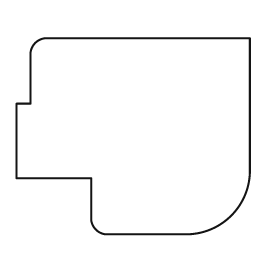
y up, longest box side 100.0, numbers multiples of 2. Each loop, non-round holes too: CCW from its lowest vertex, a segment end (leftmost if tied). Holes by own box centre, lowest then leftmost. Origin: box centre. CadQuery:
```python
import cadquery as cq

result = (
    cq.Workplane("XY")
    .moveTo(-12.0, -42.0)
    .lineTo(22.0, -42.0)
    .threePointArc((42.0, -34.0), (50.0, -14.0))
    .lineTo(50.0, 42.0)
    .lineTo(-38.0, 42.0)
    .threePointArc((-42.0, 40.0), (-44.0, 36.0))
    .lineTo(-44.0, 14.0)
    .lineTo(-50.0, 14.0)
    .lineTo(-50.0, -18.0)
    .lineTo(-18.0, -18.0)
    .lineTo(-18.0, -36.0)
    .threePointArc((-16.0, -40.0), (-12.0, -42.0))
    .close()
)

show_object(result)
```